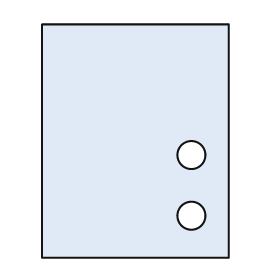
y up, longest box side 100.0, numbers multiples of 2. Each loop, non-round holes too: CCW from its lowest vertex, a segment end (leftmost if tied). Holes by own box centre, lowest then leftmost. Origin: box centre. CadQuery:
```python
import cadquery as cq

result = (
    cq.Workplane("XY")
    .moveTo(-40.0, -50.0)
    .lineTo(40.0, -50.0)
    .lineTo(40.0, 50.0)
    .lineTo(-40.0, 50.0)
    .close()
    .moveTo(24.0, -32.0)
    .circle(6.0)
    .moveTo(24.0, -6.0)
    .circle(6.0)
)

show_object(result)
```